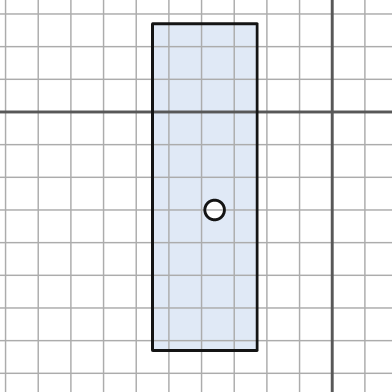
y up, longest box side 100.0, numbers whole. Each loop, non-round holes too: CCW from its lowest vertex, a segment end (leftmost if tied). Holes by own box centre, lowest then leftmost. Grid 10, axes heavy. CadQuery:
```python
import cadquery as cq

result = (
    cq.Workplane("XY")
    .moveTo(-55.0, -73.0)
    .lineTo(-23.0, -73.0)
    .lineTo(-23.0, 27.0)
    .lineTo(-55.0, 27.0)
    .close()
    .moveTo(-36.0, -30.0)
    .circle(3.0)
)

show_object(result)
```